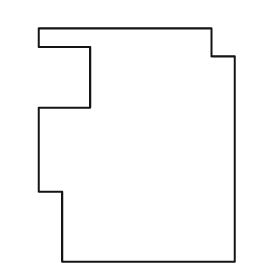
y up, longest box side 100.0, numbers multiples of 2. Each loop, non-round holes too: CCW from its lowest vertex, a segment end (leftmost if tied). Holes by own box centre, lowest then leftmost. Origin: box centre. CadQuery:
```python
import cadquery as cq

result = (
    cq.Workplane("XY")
    .moveTo(-32.0, -50.0)
    .lineTo(42.0, -50.0)
    .lineTo(42.0, 38.0)
    .lineTo(32.0, 38.0)
    .lineTo(32.0, 50.0)
    .lineTo(-42.0, 50.0)
    .lineTo(-42.0, 42.0)
    .lineTo(-20.0, 42.0)
    .lineTo(-20.0, 16.0)
    .lineTo(-42.0, 16.0)
    .lineTo(-42.0, -20.0)
    .lineTo(-32.0, -20.0)
    .close()
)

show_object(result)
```